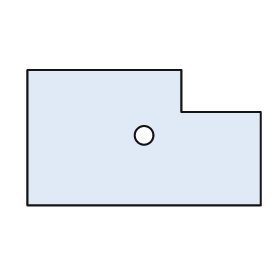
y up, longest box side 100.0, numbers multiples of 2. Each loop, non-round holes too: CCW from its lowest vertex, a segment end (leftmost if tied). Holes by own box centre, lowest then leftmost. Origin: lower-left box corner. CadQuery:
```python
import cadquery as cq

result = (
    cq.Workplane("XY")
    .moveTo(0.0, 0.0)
    .lineTo(100.0, 0.0)
    .lineTo(100.0, 40.0)
    .lineTo(66.0, 40.0)
    .lineTo(66.0, 58.0)
    .lineTo(0.0, 58.0)
    .close()
    .moveTo(50.0, 30.0)
    .circle(4.0)
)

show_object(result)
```